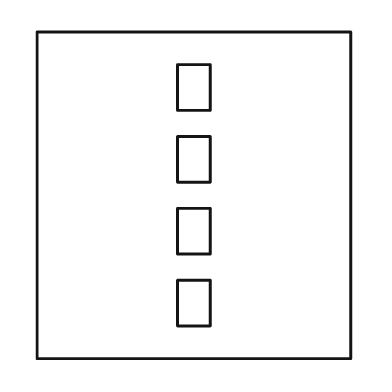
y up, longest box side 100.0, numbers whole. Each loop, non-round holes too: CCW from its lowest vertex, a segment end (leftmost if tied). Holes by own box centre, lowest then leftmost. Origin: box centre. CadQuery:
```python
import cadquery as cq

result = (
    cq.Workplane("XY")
    .moveTo(-48.0, -50.0)
    .lineTo(48.0, -50.0)
    .lineTo(48.0, 50.0)
    .lineTo(-48.0, 50.0)
    .close()
    .moveTo(-5.0, -40.0)
    .lineTo(5.0, -40.0)
    .lineTo(5.0, -26.0)
    .lineTo(-5.0, -26.0)
    .close()
    .moveTo(-5.0, -18.0)
    .lineTo(5.0, -18.0)
    .lineTo(5.0, -4.0)
    .lineTo(-5.0, -4.0)
    .close()
    .moveTo(-5.0, 4.0)
    .lineTo(5.0, 4.0)
    .lineTo(5.0, 18.0)
    .lineTo(-5.0, 18.0)
    .close()
    .moveTo(-5.0, 26.0)
    .lineTo(5.0, 26.0)
    .lineTo(5.0, 40.0)
    .lineTo(-5.0, 40.0)
    .close()
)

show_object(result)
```